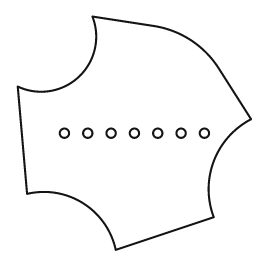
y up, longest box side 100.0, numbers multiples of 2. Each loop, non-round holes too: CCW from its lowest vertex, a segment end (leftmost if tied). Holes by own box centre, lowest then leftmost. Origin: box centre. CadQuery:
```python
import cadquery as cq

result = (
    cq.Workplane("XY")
    .moveTo(-8.0, -50.0)
    .lineTo(34.0, -36.0)
    .threePointArc((34.0, -12.0), (50.0, 6.0))
    .lineTo(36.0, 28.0)
    .threePointArc((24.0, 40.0), (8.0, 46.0))
    .lineTo(-18.0, 50.0)
    .threePointArc((-24.0, 24.0), (-50.0, 20.0))
    .lineTo(-46.0, -26.0)
    .threePointArc((-22.0, -30.0), (-8.0, -50.0))
    .close()
    .moveTo(-30.0, 0.0)
    .circle(2.0)
    .moveTo(-20.0, 0.0)
    .circle(2.0)
    .moveTo(-10.0, 0.0)
    .circle(2.0)
    .moveTo(0.0, 0.0)
    .circle(2.0)
    .moveTo(10.0, 0.0)
    .circle(2.0)
    .moveTo(20.0, 0.0)
    .circle(2.0)
    .moveTo(30.0, 0.0)
    .circle(2.0)
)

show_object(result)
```